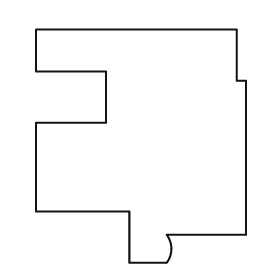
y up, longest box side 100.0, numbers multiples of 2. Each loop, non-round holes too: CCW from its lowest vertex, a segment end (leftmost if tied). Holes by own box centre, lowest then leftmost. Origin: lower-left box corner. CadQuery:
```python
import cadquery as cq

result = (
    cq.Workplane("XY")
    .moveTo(40.0, 0.0)
    .lineTo(56.0, 0.0)
    .threePointArc((58.0, 6.0), (56.0, 12.0))
    .lineTo(90.0, 12.0)
    .lineTo(90.0, 78.0)
    .lineTo(86.0, 78.0)
    .lineTo(86.0, 100.0)
    .lineTo(0.0, 100.0)
    .lineTo(0.0, 82.0)
    .lineTo(30.0, 82.0)
    .lineTo(30.0, 60.0)
    .lineTo(0.0, 60.0)
    .lineTo(0.0, 22.0)
    .lineTo(40.0, 22.0)
    .close()
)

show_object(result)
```